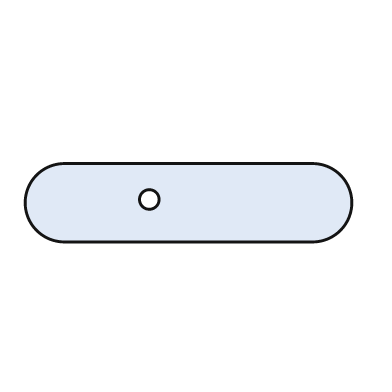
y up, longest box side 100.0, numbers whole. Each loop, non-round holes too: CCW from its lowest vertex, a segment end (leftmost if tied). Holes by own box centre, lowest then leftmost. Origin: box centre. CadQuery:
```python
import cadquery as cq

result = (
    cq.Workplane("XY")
    .moveTo(-38.0, -12.0)
    .lineTo(38.0, -12.0)
    .threePointArc((50.0, 0.0), (38.0, 12.0))
    .lineTo(-38.0, 12.0)
    .threePointArc((-50.0, 0.0), (-38.0, -12.0))
    .close()
    .moveTo(-12.0, 1.0)
    .circle(3.0)
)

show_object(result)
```